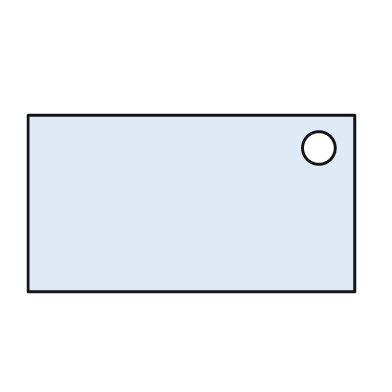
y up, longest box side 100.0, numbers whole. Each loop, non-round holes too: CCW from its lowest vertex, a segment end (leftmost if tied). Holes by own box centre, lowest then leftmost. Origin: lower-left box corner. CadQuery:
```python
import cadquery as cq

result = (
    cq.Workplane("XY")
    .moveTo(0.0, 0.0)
    .lineTo(100.0, 0.0)
    .lineTo(100.0, 54.0)
    .lineTo(0.0, 54.0)
    .close()
    .moveTo(89.0, 44.0)
    .circle(5.0)
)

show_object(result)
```